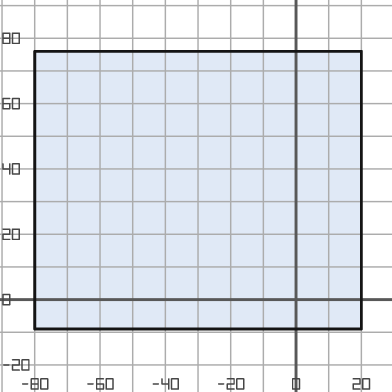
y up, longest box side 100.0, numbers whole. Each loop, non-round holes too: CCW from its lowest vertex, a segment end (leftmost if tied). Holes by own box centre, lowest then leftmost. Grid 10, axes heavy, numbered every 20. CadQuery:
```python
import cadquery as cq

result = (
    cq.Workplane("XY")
    .moveTo(-80.0, -9.0)
    .lineTo(20.0, -9.0)
    .lineTo(20.0, 76.0)
    .lineTo(-80.0, 76.0)
    .close()
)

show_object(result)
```